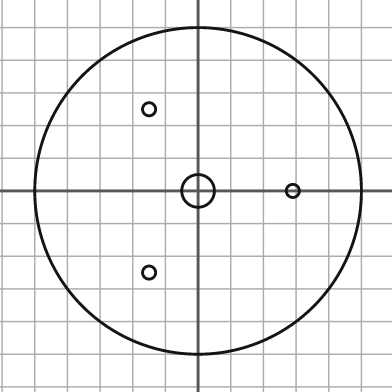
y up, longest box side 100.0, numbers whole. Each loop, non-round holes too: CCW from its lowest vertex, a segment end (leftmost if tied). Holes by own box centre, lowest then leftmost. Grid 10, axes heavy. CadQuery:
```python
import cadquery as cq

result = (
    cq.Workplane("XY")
    .moveTo(0.0, 0.0)
    .circle(50.0)
    .moveTo(-15.0, -25.0)
    .circle(2.0)
    .moveTo(0.0, 0.0)
    .circle(5.0)
    .moveTo(29.0, 0.0)
    .circle(2.0)
    .moveTo(-15.0, 25.0)
    .circle(2.0)
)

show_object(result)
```